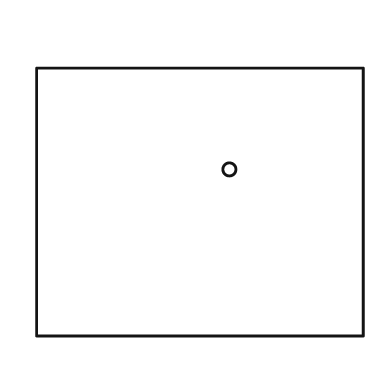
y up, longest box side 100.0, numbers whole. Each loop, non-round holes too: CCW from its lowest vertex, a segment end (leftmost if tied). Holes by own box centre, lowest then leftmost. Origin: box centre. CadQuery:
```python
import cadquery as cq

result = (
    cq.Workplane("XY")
    .moveTo(-50.0, -41.0)
    .lineTo(50.0, -41.0)
    .lineTo(50.0, 41.0)
    .lineTo(-50.0, 41.0)
    .close()
    .moveTo(9.0, 10.0)
    .circle(2.0)
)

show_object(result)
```